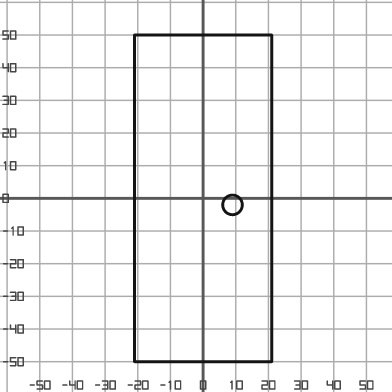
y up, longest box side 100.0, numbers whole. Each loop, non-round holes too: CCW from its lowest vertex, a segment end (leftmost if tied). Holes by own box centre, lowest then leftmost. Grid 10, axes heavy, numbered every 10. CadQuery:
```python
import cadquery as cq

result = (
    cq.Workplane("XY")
    .moveTo(-21.0, -50.0)
    .lineTo(21.0, -50.0)
    .lineTo(21.0, 50.0)
    .lineTo(-21.0, 50.0)
    .close()
    .moveTo(9.0, -2.0)
    .circle(3.0)
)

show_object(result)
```